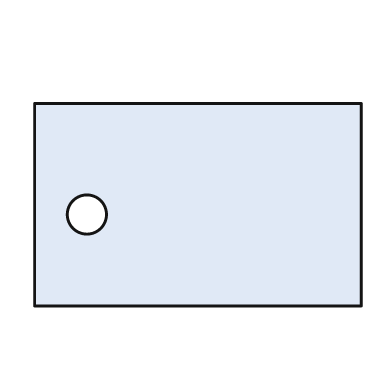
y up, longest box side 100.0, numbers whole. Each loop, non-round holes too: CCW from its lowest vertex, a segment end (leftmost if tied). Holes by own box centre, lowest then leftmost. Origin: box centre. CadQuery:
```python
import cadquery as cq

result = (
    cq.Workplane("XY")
    .moveTo(-50.0, -31.0)
    .lineTo(50.0, -31.0)
    .lineTo(50.0, 31.0)
    .lineTo(-50.0, 31.0)
    .close()
    .moveTo(-34.0, -3.0)
    .circle(6.0)
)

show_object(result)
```